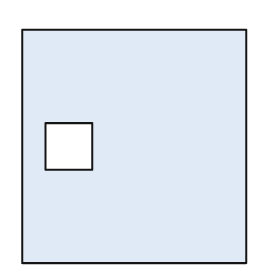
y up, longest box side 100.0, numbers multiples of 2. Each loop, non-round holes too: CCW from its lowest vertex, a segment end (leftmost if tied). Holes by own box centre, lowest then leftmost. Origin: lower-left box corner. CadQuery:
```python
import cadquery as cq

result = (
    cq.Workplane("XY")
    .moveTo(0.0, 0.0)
    .lineTo(96.0, 0.0)
    .lineTo(96.0, 100.0)
    .lineTo(0.0, 100.0)
    .close()
    .moveTo(10.0, 40.0)
    .lineTo(30.0, 40.0)
    .lineTo(30.0, 60.0)
    .lineTo(10.0, 60.0)
    .close()
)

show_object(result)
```